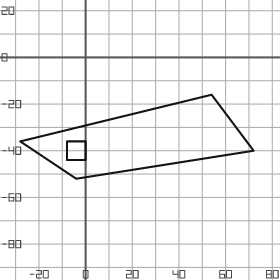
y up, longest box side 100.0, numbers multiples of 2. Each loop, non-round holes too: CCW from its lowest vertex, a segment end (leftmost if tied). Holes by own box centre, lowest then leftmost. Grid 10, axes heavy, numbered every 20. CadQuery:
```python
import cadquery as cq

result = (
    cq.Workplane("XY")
    .moveTo(-4.0, -52.0)
    .lineTo(72.0, -40.0)
    .lineTo(54.0, -16.0)
    .lineTo(-28.0, -36.0)
    .close()
    .moveTo(-8.0, -44.0)
    .lineTo(0.0, -44.0)
    .lineTo(0.0, -36.0)
    .lineTo(-8.0, -36.0)
    .close()
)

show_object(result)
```